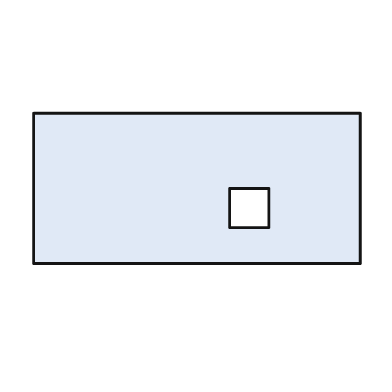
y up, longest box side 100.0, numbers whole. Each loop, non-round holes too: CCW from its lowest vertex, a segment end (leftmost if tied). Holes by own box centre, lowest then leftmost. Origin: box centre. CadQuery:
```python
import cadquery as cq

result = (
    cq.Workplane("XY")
    .moveTo(-50.0, -23.0)
    .lineTo(50.0, -23.0)
    .lineTo(50.0, 23.0)
    .lineTo(-50.0, 23.0)
    .close()
    .moveTo(10.0, -12.0)
    .lineTo(22.0, -12.0)
    .lineTo(22.0, 0.0)
    .lineTo(10.0, 0.0)
    .close()
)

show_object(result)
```